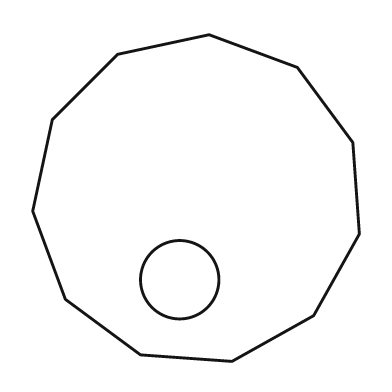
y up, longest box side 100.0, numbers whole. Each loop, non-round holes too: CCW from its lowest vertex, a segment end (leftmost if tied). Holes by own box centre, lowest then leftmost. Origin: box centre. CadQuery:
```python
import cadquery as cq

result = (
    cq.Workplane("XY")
    .moveTo(11.0, -50.0)
    .lineTo(36.0, -36.0)
    .lineTo(50.0, -11.0)
    .lineTo(48.0, 17.0)
    .lineTo(31.0, 40.0)
    .lineTo(4.0, 50.0)
    .lineTo(-24.0, 44.0)
    .lineTo(-44.0, 24.0)
    .lineTo(-50.0, -4.0)
    .lineTo(-40.0, -31.0)
    .lineTo(-17.0, -48.0)
    .close()
    .moveTo(-5.0, -25.0)
    .circle(12.0)
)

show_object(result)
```